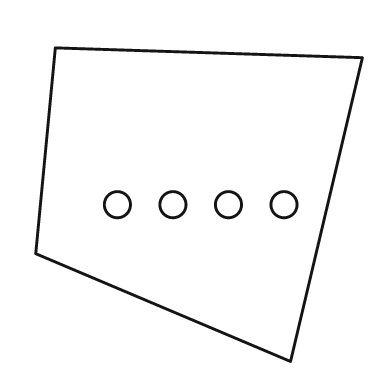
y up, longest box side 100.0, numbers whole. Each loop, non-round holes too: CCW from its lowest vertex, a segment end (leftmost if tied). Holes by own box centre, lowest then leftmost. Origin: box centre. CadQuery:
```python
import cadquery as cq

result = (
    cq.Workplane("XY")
    .moveTo(28.0, -48.0)
    .lineTo(50.0, 45.0)
    .lineTo(-44.0, 48.0)
    .lineTo(-50.0, -15.0)
    .close()
    .moveTo(-25.0, 0.0)
    .circle(4.0)
    .moveTo(-8.0, 0.0)
    .circle(4.0)
    .moveTo(9.0, 0.0)
    .circle(4.0)
    .moveTo(26.0, 0.0)
    .circle(4.0)
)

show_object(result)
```